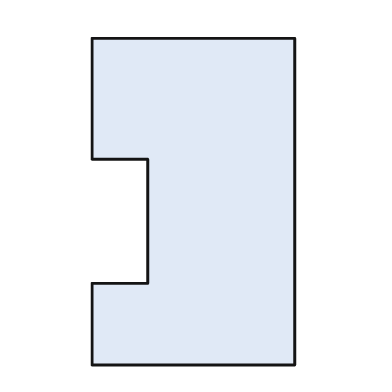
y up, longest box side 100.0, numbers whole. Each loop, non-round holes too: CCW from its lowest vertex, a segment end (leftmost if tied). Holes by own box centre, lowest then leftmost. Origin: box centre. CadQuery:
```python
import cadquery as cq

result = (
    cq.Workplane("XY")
    .moveTo(-31.0, -50.0)
    .lineTo(31.0, -50.0)
    .lineTo(31.0, 50.0)
    .lineTo(-31.0, 50.0)
    .lineTo(-31.0, 13.0)
    .lineTo(-14.0, 13.0)
    .lineTo(-14.0, -25.0)
    .lineTo(-31.0, -25.0)
    .close()
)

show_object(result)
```